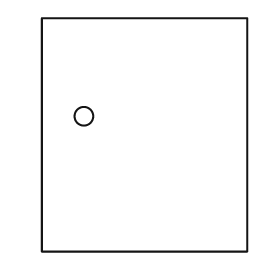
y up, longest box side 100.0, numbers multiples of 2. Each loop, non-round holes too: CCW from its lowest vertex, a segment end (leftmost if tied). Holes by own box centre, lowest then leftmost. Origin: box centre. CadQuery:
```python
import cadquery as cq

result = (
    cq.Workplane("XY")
    .moveTo(-44.0, -50.0)
    .lineTo(44.0, -50.0)
    .lineTo(44.0, 50.0)
    .lineTo(-44.0, 50.0)
    .close()
    .moveTo(-26.0, 8.0)
    .circle(4.0)
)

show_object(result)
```